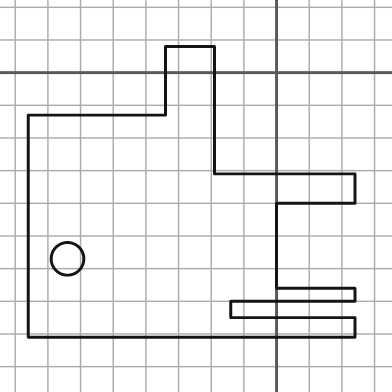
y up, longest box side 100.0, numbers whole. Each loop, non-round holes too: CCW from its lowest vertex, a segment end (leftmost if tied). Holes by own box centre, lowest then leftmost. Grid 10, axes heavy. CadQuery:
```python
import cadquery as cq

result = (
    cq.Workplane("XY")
    .moveTo(-76.0, -81.0)
    .lineTo(24.0, -81.0)
    .lineTo(24.0, -75.0)
    .lineTo(-14.0, -75.0)
    .lineTo(-14.0, -70.0)
    .lineTo(24.0, -70.0)
    .lineTo(24.0, -66.0)
    .lineTo(0.0, -66.0)
    .lineTo(0.0, -40.0)
    .lineTo(24.0, -40.0)
    .lineTo(24.0, -31.0)
    .lineTo(-19.0, -31.0)
    .lineTo(-19.0, 8.0)
    .lineTo(-34.0, 8.0)
    .lineTo(-34.0, -13.0)
    .lineTo(-76.0, -13.0)
    .close()
    .moveTo(-64.0, -57.0)
    .circle(5.0)
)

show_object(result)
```